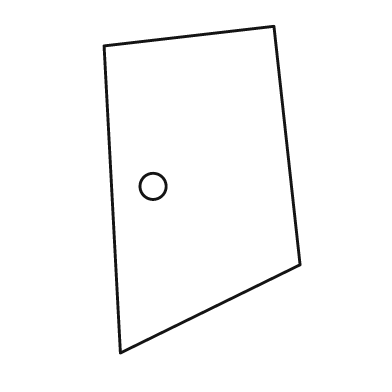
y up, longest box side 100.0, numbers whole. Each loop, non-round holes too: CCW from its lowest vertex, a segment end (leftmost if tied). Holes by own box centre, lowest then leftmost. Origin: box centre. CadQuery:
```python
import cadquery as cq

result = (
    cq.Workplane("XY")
    .moveTo(-25.0, -50.0)
    .lineTo(30.0, -23.0)
    .lineTo(22.0, 50.0)
    .lineTo(-30.0, 44.0)
    .close()
    .moveTo(-15.0, 1.0)
    .circle(4.0)
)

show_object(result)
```